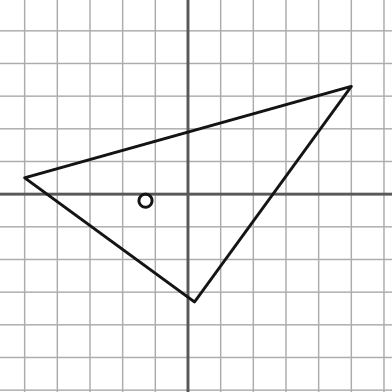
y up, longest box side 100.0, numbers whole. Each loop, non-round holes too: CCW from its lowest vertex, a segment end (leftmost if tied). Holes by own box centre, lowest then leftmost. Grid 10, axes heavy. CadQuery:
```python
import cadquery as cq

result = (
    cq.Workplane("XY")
    .moveTo(2.0, -33.0)
    .lineTo(50.0, 33.0)
    .lineTo(-50.0, 5.0)
    .close()
    .moveTo(-13.0, -2.0)
    .circle(2.0)
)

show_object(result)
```